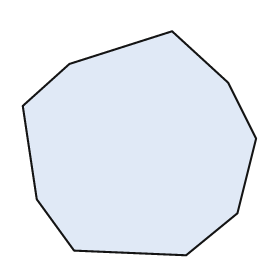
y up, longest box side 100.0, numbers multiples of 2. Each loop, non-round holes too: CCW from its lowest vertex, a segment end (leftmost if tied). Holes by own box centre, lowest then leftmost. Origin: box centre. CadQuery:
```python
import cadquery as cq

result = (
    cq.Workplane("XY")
    .moveTo(20.0, -48.0)
    .lineTo(42.0, -30.0)
    .lineTo(50.0, 2.0)
    .lineTo(38.0, 26.0)
    .lineTo(14.0, 48.0)
    .lineTo(-30.0, 34.0)
    .lineTo(-50.0, 16.0)
    .lineTo(-44.0, -24.0)
    .lineTo(-28.0, -46.0)
    .close()
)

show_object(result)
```